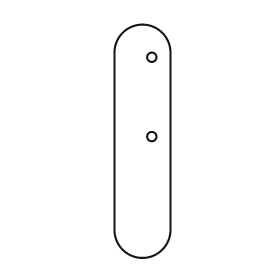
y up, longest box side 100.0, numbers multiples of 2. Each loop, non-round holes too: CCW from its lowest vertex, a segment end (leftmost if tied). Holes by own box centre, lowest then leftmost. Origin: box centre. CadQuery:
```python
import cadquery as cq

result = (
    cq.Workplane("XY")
    .moveTo(-12.0, -38.0)
    .threePointArc((0.0, -50.0), (12.0, -38.0))
    .lineTo(12.0, 38.0)
    .threePointArc((0.0, 50.0), (-12.0, 38.0))
    .close()
    .moveTo(4.0, 2.0)
    .circle(2.0)
    .moveTo(4.0, 36.0)
    .circle(2.0)
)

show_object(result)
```